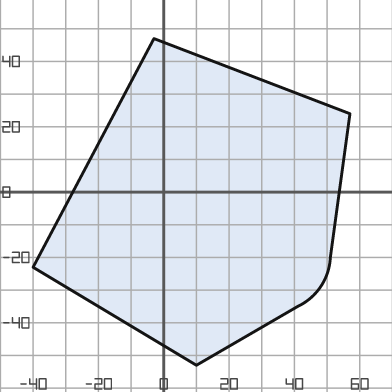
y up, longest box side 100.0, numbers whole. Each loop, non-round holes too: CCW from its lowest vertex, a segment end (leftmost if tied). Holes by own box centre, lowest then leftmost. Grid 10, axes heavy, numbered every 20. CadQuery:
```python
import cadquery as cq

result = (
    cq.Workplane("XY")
    .moveTo(10.0, -53.0)
    .lineTo(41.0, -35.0)
    .threePointArc((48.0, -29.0), (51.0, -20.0))
    .lineTo(57.0, 24.0)
    .lineTo(-3.0, 47.0)
    .lineTo(-40.0, -23.0)
    .close()
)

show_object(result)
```